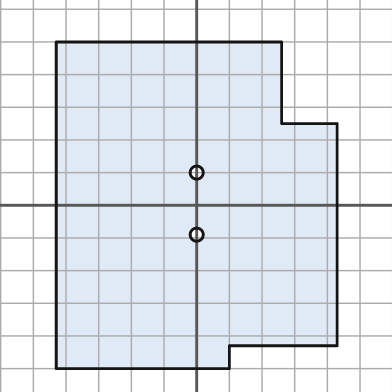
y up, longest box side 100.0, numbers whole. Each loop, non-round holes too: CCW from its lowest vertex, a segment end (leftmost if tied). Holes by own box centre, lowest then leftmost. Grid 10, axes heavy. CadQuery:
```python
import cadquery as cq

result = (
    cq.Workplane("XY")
    .moveTo(-43.0, -50.0)
    .lineTo(10.0, -50.0)
    .lineTo(10.0, -43.0)
    .lineTo(43.0, -43.0)
    .lineTo(43.0, 25.0)
    .lineTo(26.0, 25.0)
    .lineTo(26.0, 50.0)
    .lineTo(-43.0, 50.0)
    .close()
    .moveTo(0.0, -9.0)
    .circle(2.0)
    .moveTo(0.0, 10.0)
    .circle(2.0)
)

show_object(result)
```